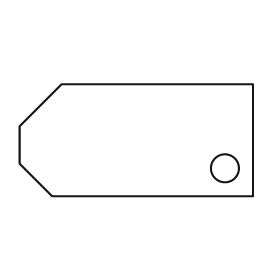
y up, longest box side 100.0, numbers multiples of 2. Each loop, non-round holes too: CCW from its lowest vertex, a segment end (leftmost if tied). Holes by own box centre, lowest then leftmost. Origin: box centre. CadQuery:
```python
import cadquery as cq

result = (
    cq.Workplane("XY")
    .moveTo(-36.0, -24.0)
    .lineTo(50.0, -24.0)
    .lineTo(50.0, 24.0)
    .lineTo(-32.0, 24.0)
    .lineTo(-50.0, 6.0)
    .lineTo(-50.0, -10.0)
    .close()
    .moveTo(38.0, -12.0)
    .circle(6.0)
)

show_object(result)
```